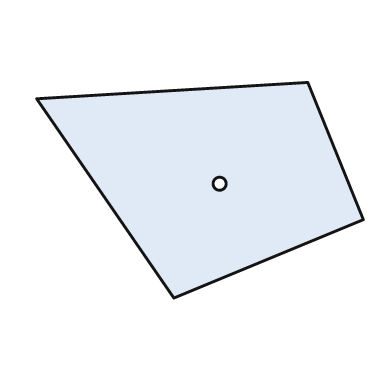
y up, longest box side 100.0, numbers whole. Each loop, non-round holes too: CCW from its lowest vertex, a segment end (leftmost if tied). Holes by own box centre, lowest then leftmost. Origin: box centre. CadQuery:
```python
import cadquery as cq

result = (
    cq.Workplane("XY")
    .moveTo(-8.0, -33.0)
    .lineTo(50.0, -9.0)
    .lineTo(33.0, 33.0)
    .lineTo(-50.0, 28.0)
    .close()
    .moveTo(6.0, 2.0)
    .circle(2.0)
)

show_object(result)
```